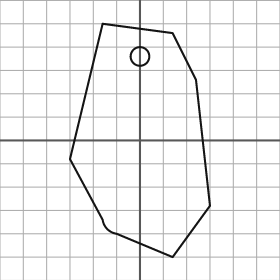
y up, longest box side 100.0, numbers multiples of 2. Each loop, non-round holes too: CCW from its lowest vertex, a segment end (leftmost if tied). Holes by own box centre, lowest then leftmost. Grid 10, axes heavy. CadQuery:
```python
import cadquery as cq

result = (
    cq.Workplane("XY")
    .moveTo(14.0, -50.0)
    .lineTo(30.0, -28.0)
    .lineTo(24.0, 26.0)
    .lineTo(14.0, 46.0)
    .lineTo(-16.0, 50.0)
    .lineTo(-30.0, -8.0)
    .lineTo(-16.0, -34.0)
    .threePointArc((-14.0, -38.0), (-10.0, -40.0))
    .close()
    .moveTo(0.0, 36.0)
    .circle(4.0)
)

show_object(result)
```